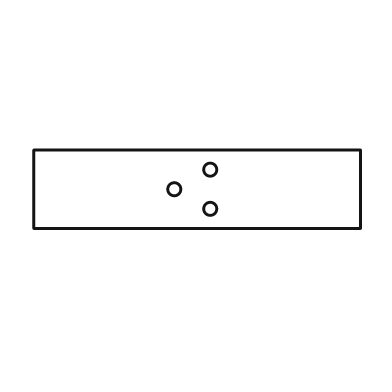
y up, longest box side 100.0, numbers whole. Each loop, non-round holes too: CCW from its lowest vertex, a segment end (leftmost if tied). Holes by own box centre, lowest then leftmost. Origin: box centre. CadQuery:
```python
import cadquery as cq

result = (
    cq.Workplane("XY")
    .moveTo(-50.0, -12.0)
    .lineTo(50.0, -12.0)
    .lineTo(50.0, 12.0)
    .lineTo(-50.0, 12.0)
    .close()
    .moveTo(4.0, -6.0)
    .circle(2.0)
    .moveTo(-7.0, 0.0)
    .circle(2.0)
    .moveTo(4.0, 6.0)
    .circle(2.0)
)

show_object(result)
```